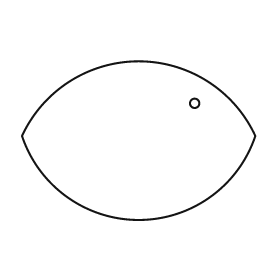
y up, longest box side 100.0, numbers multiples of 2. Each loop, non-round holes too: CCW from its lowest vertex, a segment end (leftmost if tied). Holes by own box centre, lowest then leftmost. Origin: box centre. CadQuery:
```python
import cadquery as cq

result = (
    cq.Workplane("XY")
    .moveTo(-50.0, 2.0)
    .threePointArc((0.0, -34.0), (50.0, 2.0))
    .threePointArc((0.0, 34.0), (-50.0, 2.0))
    .close()
    .moveTo(24.0, 16.0)
    .circle(2.0)
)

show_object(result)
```